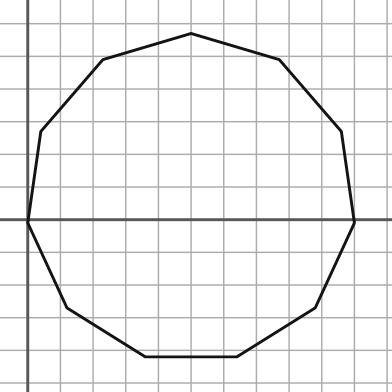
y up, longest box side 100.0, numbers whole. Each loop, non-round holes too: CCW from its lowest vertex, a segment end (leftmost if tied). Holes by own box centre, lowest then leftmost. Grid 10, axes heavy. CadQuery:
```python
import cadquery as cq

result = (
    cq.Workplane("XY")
    .moveTo(36.0, -42.0)
    .lineTo(64.0, -42.0)
    .lineTo(88.0, -27.0)
    .lineTo(100.0, -1.0)
    .lineTo(96.0, 27.0)
    .lineTo(77.0, 49.0)
    .lineTo(50.0, 57.0)
    .lineTo(23.0, 49.0)
    .lineTo(4.0, 27.0)
    .lineTo(0.0, -1.0)
    .lineTo(12.0, -27.0)
    .close()
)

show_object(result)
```